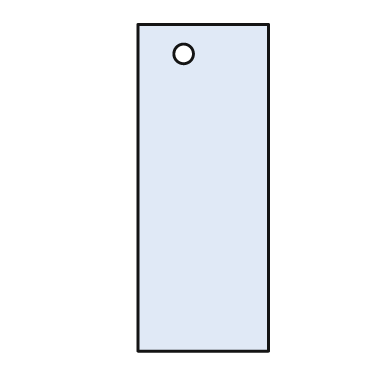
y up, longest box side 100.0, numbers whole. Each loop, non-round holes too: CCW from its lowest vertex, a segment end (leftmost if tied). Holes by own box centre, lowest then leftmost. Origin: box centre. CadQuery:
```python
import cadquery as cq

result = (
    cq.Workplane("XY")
    .moveTo(-20.0, -50.0)
    .lineTo(20.0, -50.0)
    .lineTo(20.0, 50.0)
    .lineTo(-20.0, 50.0)
    .close()
    .moveTo(-6.0, 41.0)
    .circle(3.0)
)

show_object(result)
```